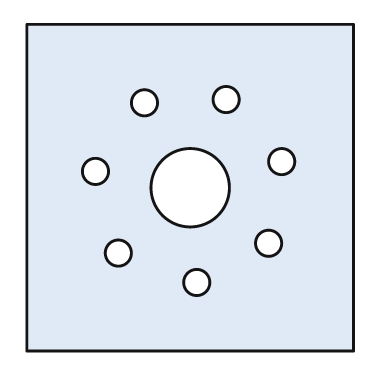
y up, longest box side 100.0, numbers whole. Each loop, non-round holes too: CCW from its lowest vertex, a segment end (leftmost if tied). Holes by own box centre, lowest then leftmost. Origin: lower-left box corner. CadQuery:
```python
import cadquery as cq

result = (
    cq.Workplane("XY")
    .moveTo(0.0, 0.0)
    .lineTo(100.0, 0.0)
    .lineTo(100.0, 100.0)
    .lineTo(0.0, 100.0)
    .close()
    .moveTo(52.0, 21.0)
    .circle(4.0)
    .moveTo(28.0, 30.0)
    .circle(4.0)
    .moveTo(74.0, 33.0)
    .circle(4.0)
    .moveTo(50.0, 50.0)
    .circle(12.0)
    .moveTo(21.0, 55.0)
    .circle(4.0)
    .moveTo(78.0, 58.0)
    .circle(4.0)
    .moveTo(36.0, 76.0)
    .circle(4.0)
    .moveTo(61.0, 77.0)
    .circle(4.0)
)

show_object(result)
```